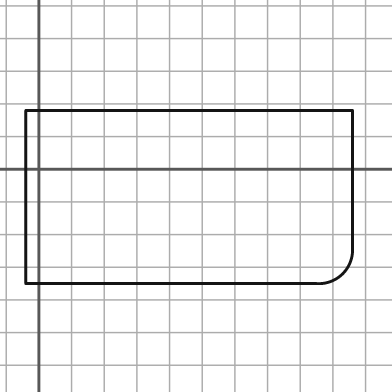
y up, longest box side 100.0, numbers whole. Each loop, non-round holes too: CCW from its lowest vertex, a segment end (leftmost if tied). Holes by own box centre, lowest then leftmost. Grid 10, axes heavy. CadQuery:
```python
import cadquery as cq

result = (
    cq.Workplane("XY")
    .moveTo(-4.0, -35.0)
    .lineTo(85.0, -35.0)
    .threePointArc((93.0, -32.0), (96.0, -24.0))
    .lineTo(96.0, 18.0)
    .lineTo(-4.0, 18.0)
    .close()
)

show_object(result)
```